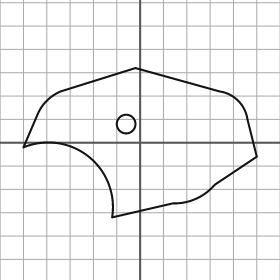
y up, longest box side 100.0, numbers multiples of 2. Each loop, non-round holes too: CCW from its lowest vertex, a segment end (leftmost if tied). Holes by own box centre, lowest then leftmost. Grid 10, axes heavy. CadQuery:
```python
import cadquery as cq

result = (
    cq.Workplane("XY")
    .moveTo(-12.0, -32.0)
    .lineTo(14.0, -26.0)
    .threePointArc((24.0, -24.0), (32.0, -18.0))
    .lineTo(50.0, -6.0)
    .lineTo(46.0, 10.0)
    .threePointArc((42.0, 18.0), (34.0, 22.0))
    .lineTo(-2.0, 32.0)
    .lineTo(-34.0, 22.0)
    .threePointArc((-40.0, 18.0), (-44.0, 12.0))
    .lineTo(-50.0, -2.0)
    .threePointArc((-22.0, -6.0), (-12.0, -32.0))
    .close()
    .moveTo(-6.0, 8.0)
    .circle(4.0)
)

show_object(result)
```